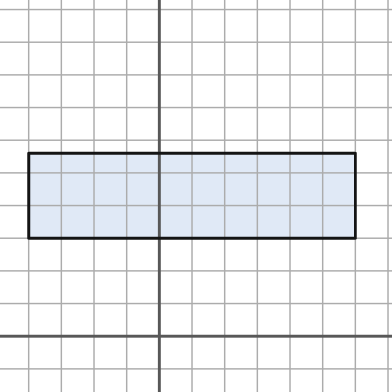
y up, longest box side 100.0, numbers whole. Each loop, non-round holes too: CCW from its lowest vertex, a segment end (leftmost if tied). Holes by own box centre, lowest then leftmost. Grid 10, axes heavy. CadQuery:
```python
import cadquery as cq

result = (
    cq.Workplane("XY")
    .moveTo(-40.0, 30.0)
    .lineTo(60.0, 30.0)
    .lineTo(60.0, 56.0)
    .lineTo(-40.0, 56.0)
    .close()
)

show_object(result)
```